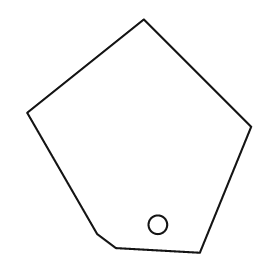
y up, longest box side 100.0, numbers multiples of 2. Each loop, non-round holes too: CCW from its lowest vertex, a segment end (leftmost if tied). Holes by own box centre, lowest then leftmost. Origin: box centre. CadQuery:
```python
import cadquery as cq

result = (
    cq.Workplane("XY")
    .moveTo(26.0, -50.0)
    .lineTo(48.0, 4.0)
    .lineTo(2.0, 50.0)
    .lineTo(-48.0, 10.0)
    .lineTo(-18.0, -42.0)
    .lineTo(-10.0, -48.0)
    .close()
    .moveTo(8.0, -38.0)
    .circle(4.0)
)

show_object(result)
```